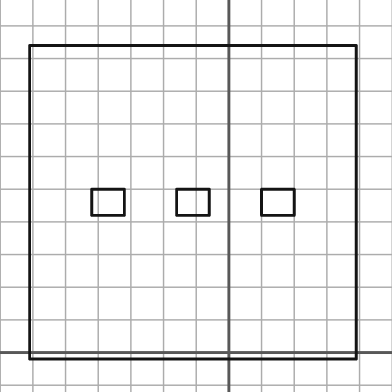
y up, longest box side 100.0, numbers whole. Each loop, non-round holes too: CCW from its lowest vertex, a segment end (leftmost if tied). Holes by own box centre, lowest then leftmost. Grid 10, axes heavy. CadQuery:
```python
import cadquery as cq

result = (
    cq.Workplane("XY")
    .moveTo(-61.0, -2.0)
    .lineTo(39.0, -2.0)
    .lineTo(39.0, 94.0)
    .lineTo(-61.0, 94.0)
    .close()
    .moveTo(-42.0, 42.0)
    .lineTo(-32.0, 42.0)
    .lineTo(-32.0, 50.0)
    .lineTo(-42.0, 50.0)
    .close()
    .moveTo(-16.0, 42.0)
    .lineTo(-6.0, 42.0)
    .lineTo(-6.0, 50.0)
    .lineTo(-16.0, 50.0)
    .close()
    .moveTo(10.0, 42.0)
    .lineTo(20.0, 42.0)
    .lineTo(20.0, 50.0)
    .lineTo(10.0, 50.0)
    .close()
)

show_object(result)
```